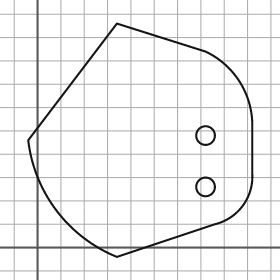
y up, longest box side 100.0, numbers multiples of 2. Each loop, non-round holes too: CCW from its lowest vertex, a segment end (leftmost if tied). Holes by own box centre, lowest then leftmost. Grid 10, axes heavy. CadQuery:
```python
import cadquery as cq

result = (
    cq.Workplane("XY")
    .moveTo(34.0, -4.0)
    .lineTo(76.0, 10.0)
    .threePointArc((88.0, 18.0), (92.0, 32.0))
    .lineTo(92.0, 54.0)
    .threePointArc((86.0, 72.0), (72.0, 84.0))
    .lineTo(34.0, 96.0)
    .lineTo(-4.0, 46.0)
    .threePointArc((8.0, 16.0), (34.0, -4.0))
    .close()
    .moveTo(72.0, 26.0)
    .circle(4.0)
    .moveTo(72.0, 48.0)
    .circle(4.0)
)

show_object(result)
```